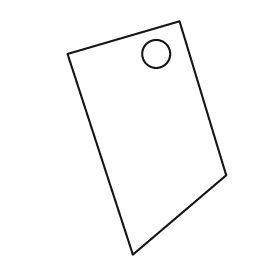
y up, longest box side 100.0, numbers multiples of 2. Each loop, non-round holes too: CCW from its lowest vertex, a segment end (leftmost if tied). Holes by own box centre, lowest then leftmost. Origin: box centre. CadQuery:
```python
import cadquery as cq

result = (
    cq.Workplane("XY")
    .moveTo(-6.0, -50.0)
    .lineTo(34.0, -16.0)
    .lineTo(14.0, 50.0)
    .lineTo(-34.0, 36.0)
    .close()
    .moveTo(4.0, 36.0)
    .circle(6.0)
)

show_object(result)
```